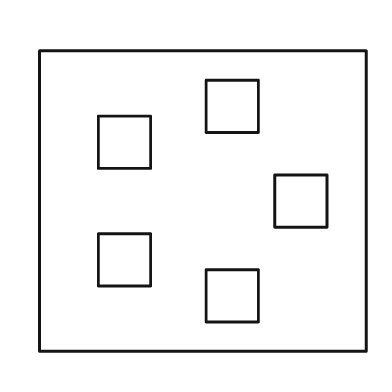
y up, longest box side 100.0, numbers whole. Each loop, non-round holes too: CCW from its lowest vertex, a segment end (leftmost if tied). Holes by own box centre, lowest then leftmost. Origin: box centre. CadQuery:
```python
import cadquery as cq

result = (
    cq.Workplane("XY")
    .moveTo(-50.0, -46.0)
    .lineTo(50.0, -46.0)
    .lineTo(50.0, 46.0)
    .lineTo(-50.0, 46.0)
    .close()
    .moveTo(1.0, -37.0)
    .lineTo(17.0, -37.0)
    .lineTo(17.0, -21.0)
    .lineTo(1.0, -21.0)
    .close()
    .moveTo(-32.0, -26.0)
    .lineTo(-16.0, -26.0)
    .lineTo(-16.0, -10.0)
    .lineTo(-32.0, -10.0)
    .close()
    .moveTo(22.0, -8.0)
    .lineTo(38.0, -8.0)
    .lineTo(38.0, 8.0)
    .lineTo(22.0, 8.0)
    .close()
    .moveTo(-32.0, 10.0)
    .lineTo(-16.0, 10.0)
    .lineTo(-16.0, 26.0)
    .lineTo(-32.0, 26.0)
    .close()
    .moveTo(1.0, 21.0)
    .lineTo(17.0, 21.0)
    .lineTo(17.0, 37.0)
    .lineTo(1.0, 37.0)
    .close()
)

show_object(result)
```